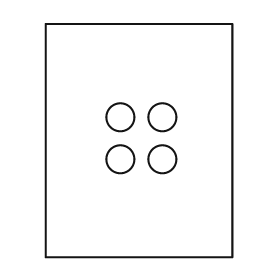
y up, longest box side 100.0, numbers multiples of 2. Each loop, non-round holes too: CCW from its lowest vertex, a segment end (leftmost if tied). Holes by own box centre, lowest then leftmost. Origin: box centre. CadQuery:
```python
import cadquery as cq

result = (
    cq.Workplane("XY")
    .moveTo(-40.0, -50.0)
    .lineTo(40.0, -50.0)
    .lineTo(40.0, 50.0)
    .lineTo(-40.0, 50.0)
    .close()
    .moveTo(-8.0, -8.0)
    .circle(6.0)
    .moveTo(10.0, -8.0)
    .circle(6.0)
    .moveTo(-8.0, 10.0)
    .circle(6.0)
    .moveTo(10.0, 10.0)
    .circle(6.0)
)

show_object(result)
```